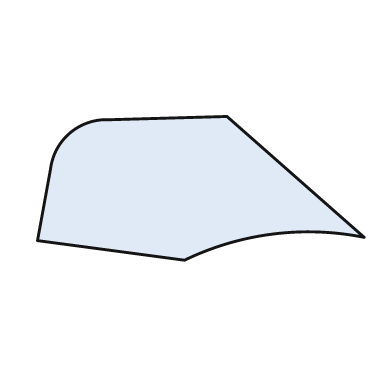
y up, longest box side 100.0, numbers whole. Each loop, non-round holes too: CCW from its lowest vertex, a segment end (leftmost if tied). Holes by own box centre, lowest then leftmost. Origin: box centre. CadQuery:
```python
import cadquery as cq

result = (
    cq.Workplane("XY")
    .moveTo(-5.0, -22.0)
    .threePointArc((22.0, -14.0), (50.0, -15.0))
    .lineTo(8.0, 22.0)
    .lineTo(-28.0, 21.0)
    .threePointArc((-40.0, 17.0), (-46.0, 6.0))
    .lineTo(-50.0, -16.0)
    .close()
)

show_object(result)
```